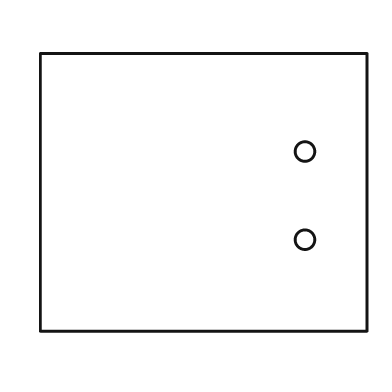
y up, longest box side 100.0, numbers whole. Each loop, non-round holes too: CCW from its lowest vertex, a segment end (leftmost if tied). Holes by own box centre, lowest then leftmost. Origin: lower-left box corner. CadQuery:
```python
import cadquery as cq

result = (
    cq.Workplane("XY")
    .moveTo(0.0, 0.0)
    .lineTo(100.0, 0.0)
    .lineTo(100.0, 85.0)
    .lineTo(0.0, 85.0)
    .close()
    .moveTo(81.0, 28.0)
    .circle(3.0)
    .moveTo(81.0, 55.0)
    .circle(3.0)
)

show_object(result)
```